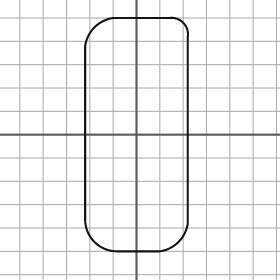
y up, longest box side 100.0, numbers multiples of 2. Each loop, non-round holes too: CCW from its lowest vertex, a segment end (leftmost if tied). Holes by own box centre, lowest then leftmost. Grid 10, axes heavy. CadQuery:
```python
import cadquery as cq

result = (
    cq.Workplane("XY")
    .moveTo(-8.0, -50.0)
    .lineTo(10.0, -50.0)
    .threePointArc((18.0, -46.0), (22.0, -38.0))
    .lineTo(22.0, 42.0)
    .threePointArc((20.0, 48.0), (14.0, 50.0))
    .lineTo(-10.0, 50.0)
    .threePointArc((-18.0, 46.0), (-22.0, 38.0))
    .lineTo(-22.0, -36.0)
    .threePointArc((-18.0, -46.0), (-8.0, -50.0))
    .close()
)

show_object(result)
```